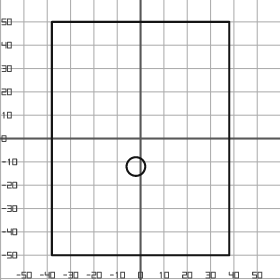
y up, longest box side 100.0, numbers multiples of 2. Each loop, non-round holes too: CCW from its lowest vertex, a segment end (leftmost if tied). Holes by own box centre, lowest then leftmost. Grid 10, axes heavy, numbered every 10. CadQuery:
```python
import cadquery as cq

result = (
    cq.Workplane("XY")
    .moveTo(-38.0, -50.0)
    .lineTo(38.0, -50.0)
    .lineTo(38.0, 50.0)
    .lineTo(-38.0, 50.0)
    .close()
    .moveTo(-2.0, -12.0)
    .circle(4.0)
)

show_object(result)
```